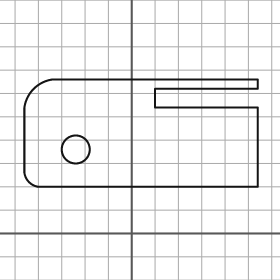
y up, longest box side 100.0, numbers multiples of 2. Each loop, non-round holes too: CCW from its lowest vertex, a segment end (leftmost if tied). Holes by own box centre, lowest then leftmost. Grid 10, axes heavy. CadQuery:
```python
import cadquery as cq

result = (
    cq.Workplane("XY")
    .moveTo(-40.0, 20.0)
    .lineTo(54.0, 20.0)
    .lineTo(54.0, 54.0)
    .lineTo(10.0, 54.0)
    .lineTo(10.0, 62.0)
    .lineTo(54.0, 62.0)
    .lineTo(54.0, 66.0)
    .lineTo(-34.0, 66.0)
    .threePointArc((-42.0, 62.0), (-46.0, 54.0))
    .lineTo(-46.0, 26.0)
    .threePointArc((-44.0, 22.0), (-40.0, 20.0))
    .close()
    .moveTo(-24.0, 36.0)
    .circle(6.0)
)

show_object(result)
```